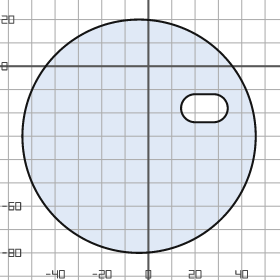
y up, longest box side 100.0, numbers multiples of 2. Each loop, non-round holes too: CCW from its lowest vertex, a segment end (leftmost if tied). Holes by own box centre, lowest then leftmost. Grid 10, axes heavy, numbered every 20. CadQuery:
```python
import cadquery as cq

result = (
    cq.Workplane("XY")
    .moveTo(-4.0, -30.0)
    .circle(50.0)
    .moveTo(20.0, -24.0)
    .lineTo(28.0, -24.0)
    .threePointArc((34.0, -18.0), (28.0, -12.0))
    .lineTo(20.0, -12.0)
    .threePointArc((14.0, -18.0), (20.0, -24.0))
    .close()
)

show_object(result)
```